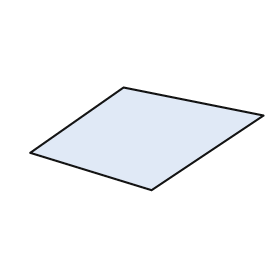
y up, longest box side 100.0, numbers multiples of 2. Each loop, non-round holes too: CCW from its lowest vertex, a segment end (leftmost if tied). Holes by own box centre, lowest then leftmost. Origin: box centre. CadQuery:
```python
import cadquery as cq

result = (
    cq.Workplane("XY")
    .moveTo(2.0, -22.0)
    .lineTo(50.0, 10.0)
    .lineTo(-10.0, 22.0)
    .lineTo(-50.0, -6.0)
    .close()
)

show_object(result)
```